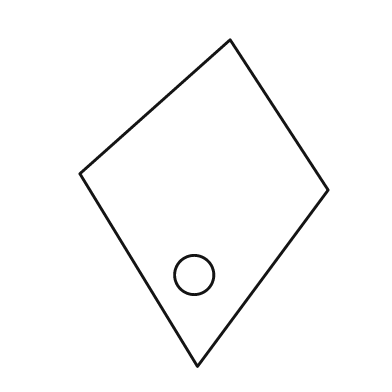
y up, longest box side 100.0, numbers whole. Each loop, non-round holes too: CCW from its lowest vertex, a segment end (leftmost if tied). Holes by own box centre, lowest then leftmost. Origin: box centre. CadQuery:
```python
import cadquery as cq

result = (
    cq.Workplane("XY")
    .moveTo(-2.0, -50.0)
    .lineTo(38.0, 4.0)
    .lineTo(8.0, 50.0)
    .lineTo(-38.0, 9.0)
    .close()
    .moveTo(-3.0, -22.0)
    .circle(6.0)
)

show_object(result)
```